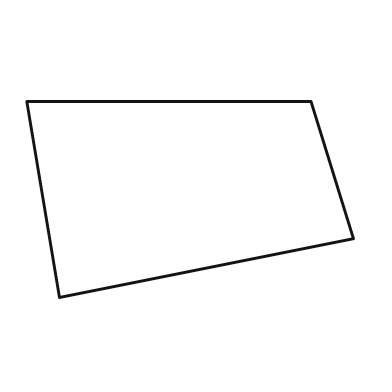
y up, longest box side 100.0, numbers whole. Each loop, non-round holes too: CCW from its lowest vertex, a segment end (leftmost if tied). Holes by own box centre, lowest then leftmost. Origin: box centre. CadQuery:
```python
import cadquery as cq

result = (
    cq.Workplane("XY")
    .moveTo(-40.0, -30.0)
    .lineTo(50.0, -12.0)
    .lineTo(37.0, 30.0)
    .lineTo(-50.0, 30.0)
    .close()
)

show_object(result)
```